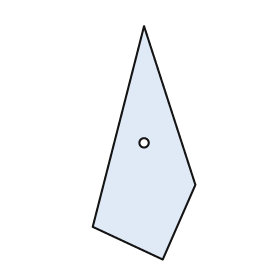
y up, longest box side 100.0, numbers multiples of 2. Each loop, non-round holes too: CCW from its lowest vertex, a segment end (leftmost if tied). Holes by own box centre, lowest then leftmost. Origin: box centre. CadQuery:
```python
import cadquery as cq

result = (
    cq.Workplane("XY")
    .moveTo(8.0, -50.0)
    .lineTo(22.0, -18.0)
    .lineTo(0.0, 50.0)
    .lineTo(-22.0, -36.0)
    .close()
    .moveTo(0.0, 0.0)
    .circle(2.0)
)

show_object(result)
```